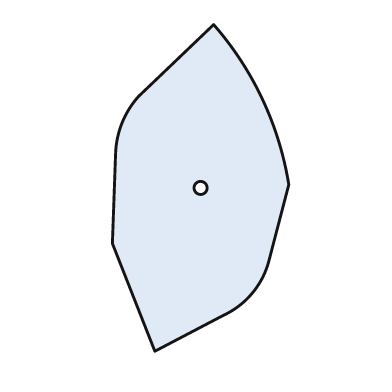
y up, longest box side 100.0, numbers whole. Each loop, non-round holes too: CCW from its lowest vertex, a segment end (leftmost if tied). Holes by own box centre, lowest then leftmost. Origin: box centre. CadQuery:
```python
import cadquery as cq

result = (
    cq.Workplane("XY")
    .moveTo(-14.0, -50.0)
    .lineTo(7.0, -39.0)
    .threePointArc((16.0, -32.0), (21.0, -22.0))
    .lineTo(27.0, 1.0)
    .threePointArc((19.0, 27.0), (4.0, 50.0))
    .lineTo(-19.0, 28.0)
    .threePointArc((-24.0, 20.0), (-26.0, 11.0))
    .lineTo(-27.0, -17.0)
    .close()
    .moveTo(0.0, 0.0)
    .circle(2.0)
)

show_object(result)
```